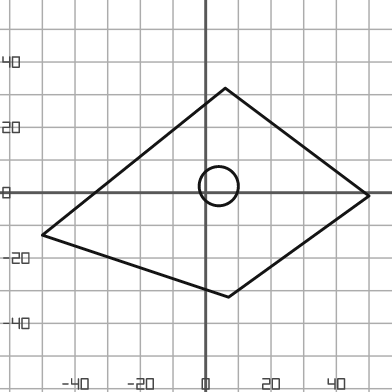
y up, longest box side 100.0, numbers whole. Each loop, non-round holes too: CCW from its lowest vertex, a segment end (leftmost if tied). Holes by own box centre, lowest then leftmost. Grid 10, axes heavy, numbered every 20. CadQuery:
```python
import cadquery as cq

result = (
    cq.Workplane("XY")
    .moveTo(7.0, -32.0)
    .lineTo(50.0, -1.0)
    .lineTo(6.0, 32.0)
    .lineTo(-50.0, -13.0)
    .close()
    .moveTo(4.0, 2.0)
    .circle(6.0)
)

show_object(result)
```